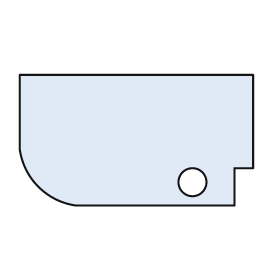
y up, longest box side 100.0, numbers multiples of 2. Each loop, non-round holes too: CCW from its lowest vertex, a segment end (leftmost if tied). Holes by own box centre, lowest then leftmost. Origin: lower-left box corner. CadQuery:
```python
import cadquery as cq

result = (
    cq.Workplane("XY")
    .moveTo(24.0, 0.0)
    .lineTo(92.0, 0.0)
    .lineTo(92.0, 16.0)
    .lineTo(100.0, 16.0)
    .lineTo(100.0, 56.0)
    .lineTo(0.0, 56.0)
    .lineTo(0.0, 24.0)
    .threePointArc((8.0, 8.0), (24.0, 0.0))
    .close()
    .moveTo(74.0, 10.0)
    .circle(6.0)
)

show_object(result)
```